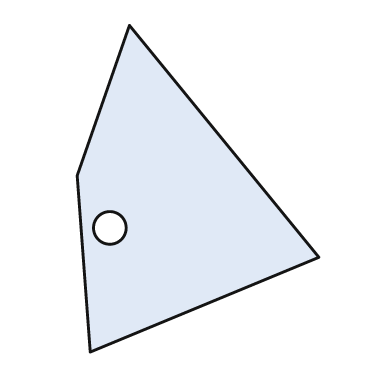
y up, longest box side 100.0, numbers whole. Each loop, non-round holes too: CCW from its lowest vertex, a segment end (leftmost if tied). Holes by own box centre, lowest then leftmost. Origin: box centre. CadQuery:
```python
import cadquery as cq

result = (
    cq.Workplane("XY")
    .moveTo(-33.0, -50.0)
    .lineTo(37.0, -21.0)
    .lineTo(-21.0, 50.0)
    .lineTo(-37.0, 4.0)
    .close()
    .moveTo(-27.0, -12.0)
    .circle(5.0)
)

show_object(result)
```